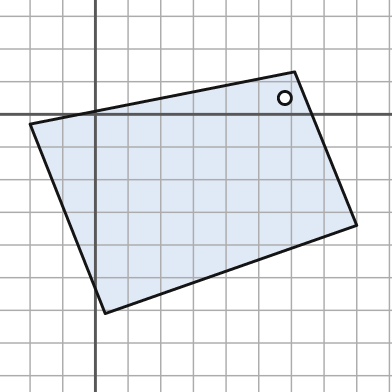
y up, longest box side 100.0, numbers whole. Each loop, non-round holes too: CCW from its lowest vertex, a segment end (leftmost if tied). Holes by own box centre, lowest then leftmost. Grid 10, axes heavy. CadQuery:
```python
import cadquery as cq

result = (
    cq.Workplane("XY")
    .moveTo(3.0, -61.0)
    .lineTo(80.0, -34.0)
    .lineTo(61.0, 13.0)
    .lineTo(-20.0, -3.0)
    .close()
    .moveTo(58.0, 5.0)
    .circle(2.0)
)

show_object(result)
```